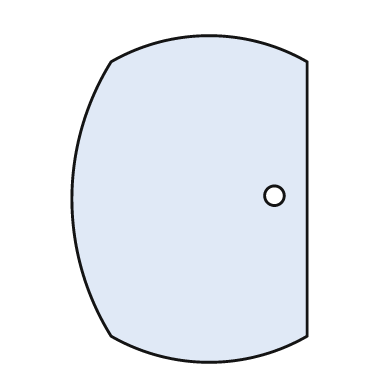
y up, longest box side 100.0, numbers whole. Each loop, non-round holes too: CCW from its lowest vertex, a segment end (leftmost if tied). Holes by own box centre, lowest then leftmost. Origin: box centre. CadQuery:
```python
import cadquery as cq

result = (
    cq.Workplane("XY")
    .moveTo(-24.0, -42.0)
    .threePointArc((6.0, -50.0), (36.0, -42.0))
    .lineTo(36.0, 42.0)
    .threePointArc((6.0, 50.0), (-24.0, 42.0))
    .threePointArc((-36.0, 0.0), (-24.0, -42.0))
    .close()
    .moveTo(26.0, 1.0)
    .circle(3.0)
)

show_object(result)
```